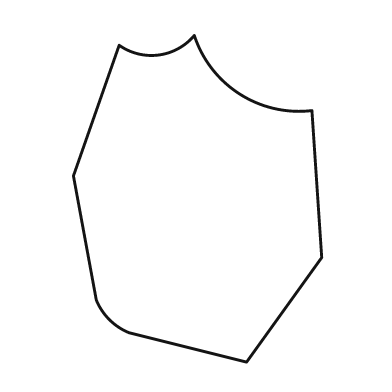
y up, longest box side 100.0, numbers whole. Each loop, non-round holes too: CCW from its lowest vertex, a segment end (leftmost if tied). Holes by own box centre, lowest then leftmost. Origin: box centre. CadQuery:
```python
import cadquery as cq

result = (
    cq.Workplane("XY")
    .moveTo(15.0, -50.0)
    .lineTo(38.0, -18.0)
    .lineTo(35.0, 27.0)
    .threePointArc((13.0, 32.0), (-1.0, 50.0))
    .threePointArc((-12.0, 44.0), (-24.0, 47.0))
    .lineTo(-38.0, 7.0)
    .lineTo(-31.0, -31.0)
    .threePointArc((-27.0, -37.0), (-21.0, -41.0))
    .close()
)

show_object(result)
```